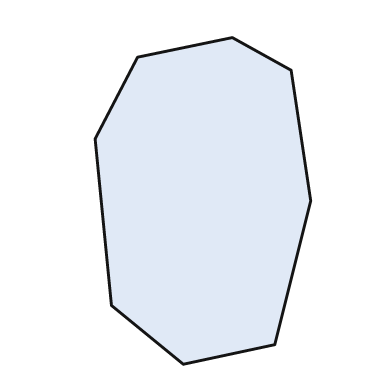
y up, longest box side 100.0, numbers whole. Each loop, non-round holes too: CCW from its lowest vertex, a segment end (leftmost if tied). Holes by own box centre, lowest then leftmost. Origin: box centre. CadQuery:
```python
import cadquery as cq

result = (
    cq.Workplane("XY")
    .moveTo(-6.0, -50.0)
    .lineTo(22.0, -44.0)
    .lineTo(33.0, 0.0)
    .lineTo(27.0, 40.0)
    .lineTo(9.0, 50.0)
    .lineTo(-20.0, 44.0)
    .lineTo(-33.0, 19.0)
    .lineTo(-28.0, -32.0)
    .close()
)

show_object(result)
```